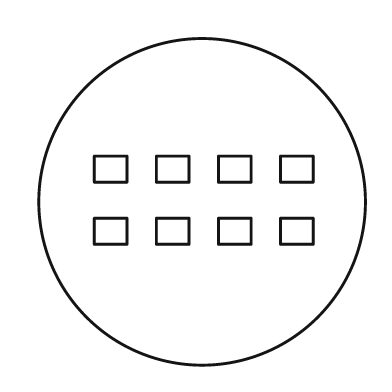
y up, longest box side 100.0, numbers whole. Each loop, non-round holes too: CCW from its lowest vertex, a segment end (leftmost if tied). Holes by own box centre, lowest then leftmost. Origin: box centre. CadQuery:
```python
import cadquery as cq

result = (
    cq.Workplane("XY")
    .moveTo(0.0, 0.0)
    .circle(50.0)
    .moveTo(-33.0, -13.0)
    .lineTo(-23.0, -13.0)
    .lineTo(-23.0, -5.0)
    .lineTo(-33.0, -5.0)
    .close()
    .moveTo(-14.0, -13.0)
    .lineTo(-4.0, -13.0)
    .lineTo(-4.0, -5.0)
    .lineTo(-14.0, -5.0)
    .close()
    .moveTo(5.0, -13.0)
    .lineTo(15.0, -13.0)
    .lineTo(15.0, -5.0)
    .lineTo(5.0, -5.0)
    .close()
    .moveTo(24.0, -13.0)
    .lineTo(34.0, -13.0)
    .lineTo(34.0, -5.0)
    .lineTo(24.0, -5.0)
    .close()
    .moveTo(-33.0, 6.0)
    .lineTo(-23.0, 6.0)
    .lineTo(-23.0, 14.0)
    .lineTo(-33.0, 14.0)
    .close()
    .moveTo(-14.0, 6.0)
    .lineTo(-4.0, 6.0)
    .lineTo(-4.0, 14.0)
    .lineTo(-14.0, 14.0)
    .close()
    .moveTo(5.0, 6.0)
    .lineTo(15.0, 6.0)
    .lineTo(15.0, 14.0)
    .lineTo(5.0, 14.0)
    .close()
    .moveTo(24.0, 6.0)
    .lineTo(34.0, 6.0)
    .lineTo(34.0, 14.0)
    .lineTo(24.0, 14.0)
    .close()
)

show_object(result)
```